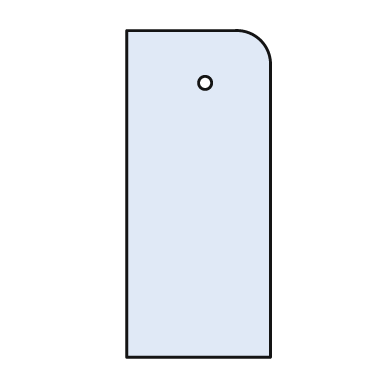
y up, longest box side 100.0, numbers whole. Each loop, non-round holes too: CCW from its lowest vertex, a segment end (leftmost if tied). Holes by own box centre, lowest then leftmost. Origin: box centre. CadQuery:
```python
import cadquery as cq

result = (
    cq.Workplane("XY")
    .moveTo(-22.0, -50.0)
    .lineTo(22.0, -50.0)
    .lineTo(22.0, 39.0)
    .threePointArc((19.0, 47.0), (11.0, 50.0))
    .lineTo(-22.0, 50.0)
    .close()
    .moveTo(2.0, 34.0)
    .circle(2.0)
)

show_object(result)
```